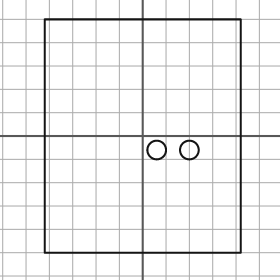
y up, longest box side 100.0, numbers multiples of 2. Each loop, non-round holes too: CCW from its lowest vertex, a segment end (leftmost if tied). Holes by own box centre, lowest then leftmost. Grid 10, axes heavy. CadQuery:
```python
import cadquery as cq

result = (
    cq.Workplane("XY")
    .moveTo(-42.0, -50.0)
    .lineTo(42.0, -50.0)
    .lineTo(42.0, 50.0)
    .lineTo(-42.0, 50.0)
    .close()
    .moveTo(6.0, -6.0)
    .circle(4.0)
    .moveTo(20.0, -6.0)
    .circle(4.0)
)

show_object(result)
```